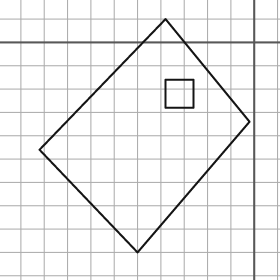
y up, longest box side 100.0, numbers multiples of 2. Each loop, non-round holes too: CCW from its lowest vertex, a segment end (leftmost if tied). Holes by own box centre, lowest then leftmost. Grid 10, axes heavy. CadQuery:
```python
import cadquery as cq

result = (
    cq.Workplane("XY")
    .moveTo(-50.0, -90.0)
    .lineTo(-2.0, -34.0)
    .lineTo(-38.0, 10.0)
    .lineTo(-92.0, -46.0)
    .close()
    .moveTo(-38.0, -28.0)
    .lineTo(-26.0, -28.0)
    .lineTo(-26.0, -16.0)
    .lineTo(-38.0, -16.0)
    .close()
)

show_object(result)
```